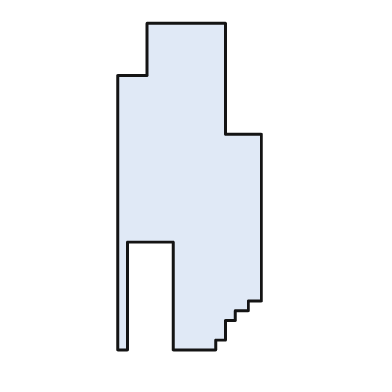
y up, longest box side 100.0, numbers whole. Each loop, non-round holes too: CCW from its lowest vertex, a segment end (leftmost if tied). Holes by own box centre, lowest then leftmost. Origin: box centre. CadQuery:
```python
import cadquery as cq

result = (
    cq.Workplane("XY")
    .moveTo(-22.0, -50.0)
    .lineTo(-19.0, -50.0)
    .lineTo(-19.0, -17.0)
    .lineTo(-5.0, -17.0)
    .lineTo(-5.0, -50.0)
    .lineTo(8.0, -50.0)
    .lineTo(8.0, -47.0)
    .lineTo(11.0, -47.0)
    .lineTo(11.0, -41.0)
    .lineTo(14.0, -41.0)
    .lineTo(14.0, -38.0)
    .lineTo(18.0, -38.0)
    .lineTo(18.0, -35.0)
    .lineTo(22.0, -35.0)
    .lineTo(22.0, 16.0)
    .lineTo(11.0, 16.0)
    .lineTo(11.0, 50.0)
    .lineTo(-13.0, 50.0)
    .lineTo(-13.0, 34.0)
    .lineTo(-22.0, 34.0)
    .close()
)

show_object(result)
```